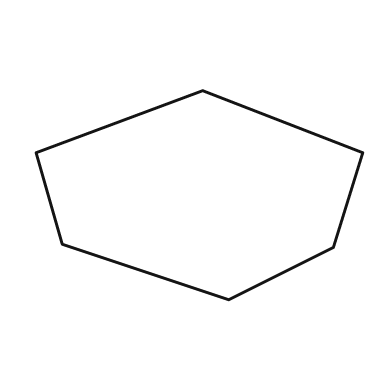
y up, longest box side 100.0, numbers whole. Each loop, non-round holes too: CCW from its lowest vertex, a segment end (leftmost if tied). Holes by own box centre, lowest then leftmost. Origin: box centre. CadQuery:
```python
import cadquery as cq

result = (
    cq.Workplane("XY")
    .moveTo(9.0, -32.0)
    .lineTo(41.0, -16.0)
    .lineTo(50.0, 13.0)
    .lineTo(1.0, 32.0)
    .lineTo(-50.0, 13.0)
    .lineTo(-42.0, -15.0)
    .close()
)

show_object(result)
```